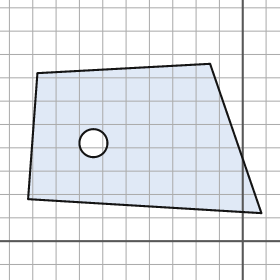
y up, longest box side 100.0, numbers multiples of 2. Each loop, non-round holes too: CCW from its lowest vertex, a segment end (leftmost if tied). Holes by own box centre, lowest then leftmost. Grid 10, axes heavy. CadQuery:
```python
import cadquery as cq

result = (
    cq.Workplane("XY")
    .moveTo(8.0, 12.0)
    .lineTo(-14.0, 76.0)
    .lineTo(-88.0, 72.0)
    .lineTo(-92.0, 18.0)
    .close()
    .moveTo(-64.0, 42.0)
    .circle(6.0)
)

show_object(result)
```